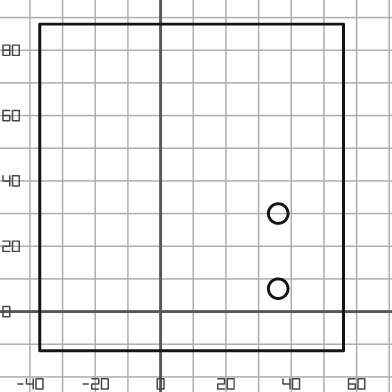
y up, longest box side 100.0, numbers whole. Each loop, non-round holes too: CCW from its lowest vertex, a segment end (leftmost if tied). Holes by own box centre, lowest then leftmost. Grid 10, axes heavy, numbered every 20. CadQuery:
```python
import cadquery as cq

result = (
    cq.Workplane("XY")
    .moveTo(-37.0, -12.0)
    .lineTo(56.0, -12.0)
    .lineTo(56.0, 88.0)
    .lineTo(-37.0, 88.0)
    .close()
    .moveTo(36.0, 7.0)
    .circle(3.0)
    .moveTo(36.0, 30.0)
    .circle(3.0)
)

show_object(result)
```